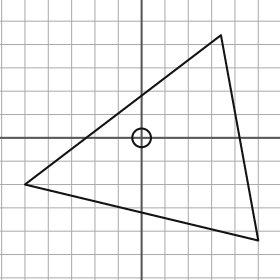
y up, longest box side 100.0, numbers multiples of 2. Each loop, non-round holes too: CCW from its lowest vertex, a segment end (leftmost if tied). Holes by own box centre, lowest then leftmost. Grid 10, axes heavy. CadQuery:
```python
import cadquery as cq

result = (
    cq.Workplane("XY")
    .moveTo(50.0, -44.0)
    .lineTo(34.0, 44.0)
    .lineTo(-50.0, -20.0)
    .close()
    .moveTo(0.0, 0.0)
    .circle(4.0)
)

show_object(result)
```